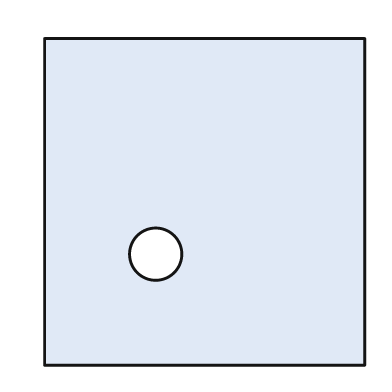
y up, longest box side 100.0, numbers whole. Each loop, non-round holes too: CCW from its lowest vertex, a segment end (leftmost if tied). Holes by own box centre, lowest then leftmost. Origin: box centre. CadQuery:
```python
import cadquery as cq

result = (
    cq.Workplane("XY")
    .moveTo(-49.0, -50.0)
    .lineTo(49.0, -50.0)
    .lineTo(49.0, 50.0)
    .lineTo(-49.0, 50.0)
    .close()
    .moveTo(-15.0, -16.0)
    .circle(8.0)
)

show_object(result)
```